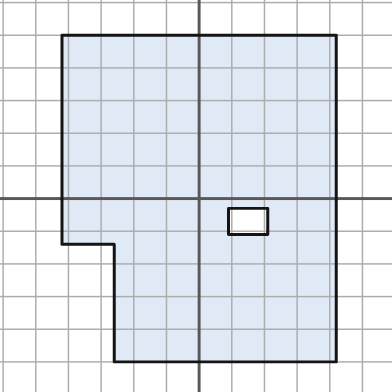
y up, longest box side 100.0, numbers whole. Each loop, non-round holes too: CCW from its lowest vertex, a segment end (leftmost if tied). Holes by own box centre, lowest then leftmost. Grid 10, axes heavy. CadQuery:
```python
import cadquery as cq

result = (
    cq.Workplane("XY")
    .moveTo(-26.0, -50.0)
    .lineTo(42.0, -50.0)
    .lineTo(42.0, 50.0)
    .lineTo(-42.0, 50.0)
    .lineTo(-42.0, -14.0)
    .lineTo(-26.0, -14.0)
    .close()
    .moveTo(9.0, -11.0)
    .lineTo(21.0, -11.0)
    .lineTo(21.0, -3.0)
    .lineTo(9.0, -3.0)
    .close()
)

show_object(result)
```